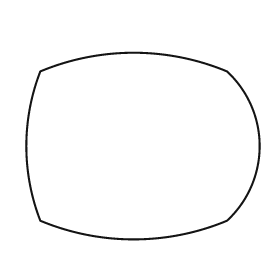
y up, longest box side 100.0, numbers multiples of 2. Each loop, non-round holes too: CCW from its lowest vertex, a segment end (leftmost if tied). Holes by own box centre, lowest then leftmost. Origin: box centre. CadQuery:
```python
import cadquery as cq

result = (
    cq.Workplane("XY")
    .moveTo(-44.0, -32.0)
    .threePointArc((-4.0, -40.0), (36.0, -32.0))
    .threePointArc((50.0, 0.0), (36.0, 32.0))
    .threePointArc((-4.0, 40.0), (-44.0, 32.0))
    .threePointArc((-50.0, 0.0), (-44.0, -32.0))
    .close()
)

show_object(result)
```